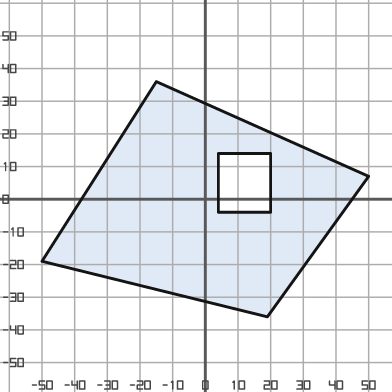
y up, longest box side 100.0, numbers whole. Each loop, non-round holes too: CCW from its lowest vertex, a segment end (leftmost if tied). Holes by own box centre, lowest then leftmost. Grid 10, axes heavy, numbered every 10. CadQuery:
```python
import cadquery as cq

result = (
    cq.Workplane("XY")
    .moveTo(19.0, -36.0)
    .lineTo(50.0, 7.0)
    .lineTo(-15.0, 36.0)
    .lineTo(-50.0, -19.0)
    .close()
    .moveTo(4.0, -4.0)
    .lineTo(20.0, -4.0)
    .lineTo(20.0, 14.0)
    .lineTo(4.0, 14.0)
    .close()
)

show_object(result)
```